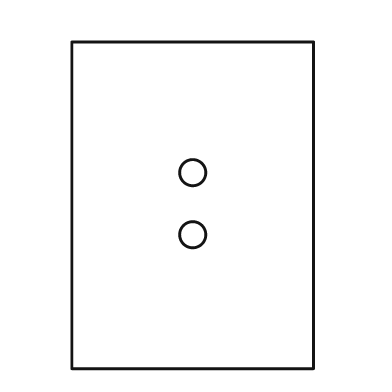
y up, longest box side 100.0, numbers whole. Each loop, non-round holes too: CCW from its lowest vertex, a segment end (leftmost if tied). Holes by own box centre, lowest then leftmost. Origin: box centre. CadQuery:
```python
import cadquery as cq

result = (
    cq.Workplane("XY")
    .moveTo(-37.0, -50.0)
    .lineTo(37.0, -50.0)
    .lineTo(37.0, 50.0)
    .lineTo(-37.0, 50.0)
    .close()
    .moveTo(0.0, -9.0)
    .circle(4.0)
    .moveTo(0.0, 10.0)
    .circle(4.0)
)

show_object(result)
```